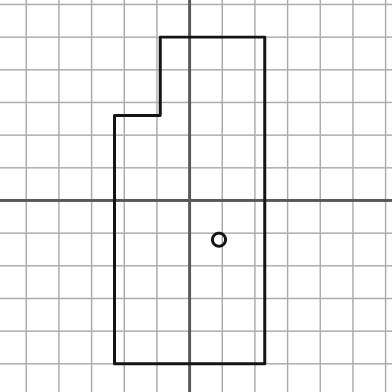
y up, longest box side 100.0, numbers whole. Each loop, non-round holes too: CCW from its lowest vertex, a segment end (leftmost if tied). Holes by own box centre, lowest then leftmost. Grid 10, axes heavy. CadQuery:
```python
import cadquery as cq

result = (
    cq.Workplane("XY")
    .moveTo(-23.0, -50.0)
    .lineTo(23.0, -50.0)
    .lineTo(23.0, 50.0)
    .lineTo(-9.0, 50.0)
    .lineTo(-9.0, 26.0)
    .lineTo(-23.0, 26.0)
    .close()
    .moveTo(9.0, -12.0)
    .circle(2.0)
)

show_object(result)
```